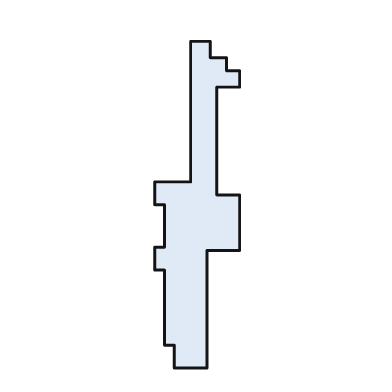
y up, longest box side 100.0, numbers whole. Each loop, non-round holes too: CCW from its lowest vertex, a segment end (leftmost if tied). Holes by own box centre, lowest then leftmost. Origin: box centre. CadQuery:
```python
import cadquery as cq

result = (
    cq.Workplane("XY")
    .moveTo(-7.0, -50.0)
    .lineTo(3.0, -50.0)
    .lineTo(3.0, -14.0)
    .lineTo(13.0, -14.0)
    .lineTo(13.0, 3.0)
    .lineTo(6.0, 3.0)
    .lineTo(6.0, 36.0)
    .lineTo(13.0, 36.0)
    .lineTo(13.0, 41.0)
    .lineTo(9.0, 41.0)
    .lineTo(9.0, 45.0)
    .lineTo(4.0, 45.0)
    .lineTo(4.0, 50.0)
    .lineTo(-2.0, 50.0)
    .lineTo(-2.0, 7.0)
    .lineTo(-13.0, 7.0)
    .lineTo(-13.0, 0.0)
    .lineTo(-10.0, 0.0)
    .lineTo(-10.0, -13.0)
    .lineTo(-13.0, -13.0)
    .lineTo(-13.0, -20.0)
    .lineTo(-10.0, -20.0)
    .lineTo(-10.0, -43.0)
    .lineTo(-7.0, -43.0)
    .close()
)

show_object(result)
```